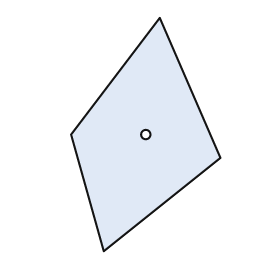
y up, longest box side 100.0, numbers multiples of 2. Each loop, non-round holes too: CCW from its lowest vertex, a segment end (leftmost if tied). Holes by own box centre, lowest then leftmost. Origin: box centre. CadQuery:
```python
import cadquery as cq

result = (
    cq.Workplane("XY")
    .moveTo(-18.0, -50.0)
    .lineTo(32.0, -10.0)
    .lineTo(6.0, 50.0)
    .lineTo(-32.0, 0.0)
    .close()
    .moveTo(0.0, 0.0)
    .circle(2.0)
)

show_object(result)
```